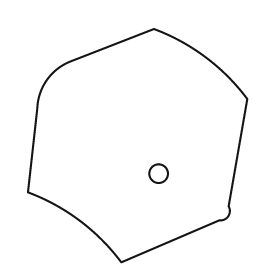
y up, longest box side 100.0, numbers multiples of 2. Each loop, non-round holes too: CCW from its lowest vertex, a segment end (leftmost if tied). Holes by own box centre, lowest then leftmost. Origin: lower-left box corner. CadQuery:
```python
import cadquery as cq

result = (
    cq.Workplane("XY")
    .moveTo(40.0, 0.0)
    .lineTo(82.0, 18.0)
    .threePointArc((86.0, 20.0), (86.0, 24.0))
    .lineTo(94.0, 70.0)
    .threePointArc((76.0, 88.0), (54.0, 100.0))
    .lineTo(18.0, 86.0)
    .threePointArc((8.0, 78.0), (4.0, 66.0))
    .lineTo(0.0, 30.0)
    .threePointArc((22.0, 18.0), (40.0, 0.0))
    .close()
    .moveTo(56.0, 38.0)
    .circle(4.0)
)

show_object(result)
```